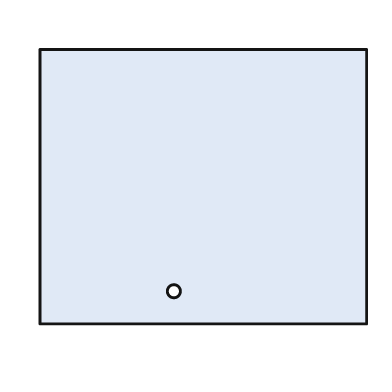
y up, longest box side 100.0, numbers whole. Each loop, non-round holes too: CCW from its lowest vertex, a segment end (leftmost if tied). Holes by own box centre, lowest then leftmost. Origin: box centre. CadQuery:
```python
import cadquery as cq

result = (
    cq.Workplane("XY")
    .moveTo(-50.0, -42.0)
    .lineTo(50.0, -42.0)
    .lineTo(50.0, 42.0)
    .lineTo(-50.0, 42.0)
    .close()
    .moveTo(-9.0, -32.0)
    .circle(2.0)
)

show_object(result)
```